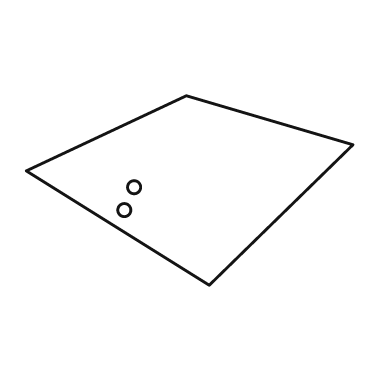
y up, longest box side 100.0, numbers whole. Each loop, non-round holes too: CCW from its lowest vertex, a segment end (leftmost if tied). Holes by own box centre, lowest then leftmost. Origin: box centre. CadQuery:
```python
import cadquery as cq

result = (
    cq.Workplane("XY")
    .moveTo(6.0, -29.0)
    .lineTo(50.0, 14.0)
    .lineTo(-1.0, 29.0)
    .lineTo(-50.0, 6.0)
    .close()
    .moveTo(-20.0, -6.0)
    .circle(2.0)
    .moveTo(-17.0, 1.0)
    .circle(2.0)
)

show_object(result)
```